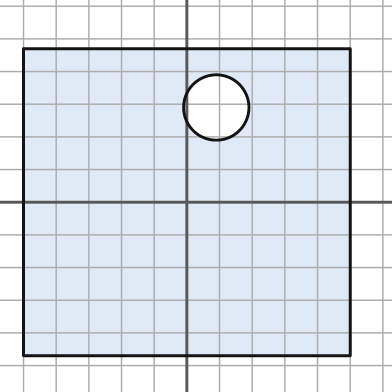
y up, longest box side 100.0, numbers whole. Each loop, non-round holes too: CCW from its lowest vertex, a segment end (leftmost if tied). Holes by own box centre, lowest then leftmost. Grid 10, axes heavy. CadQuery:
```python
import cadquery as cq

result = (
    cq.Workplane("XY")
    .moveTo(-50.0, -47.0)
    .lineTo(50.0, -47.0)
    .lineTo(50.0, 47.0)
    .lineTo(-50.0, 47.0)
    .close()
    .moveTo(9.0, 29.0)
    .circle(10.0)
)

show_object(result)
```